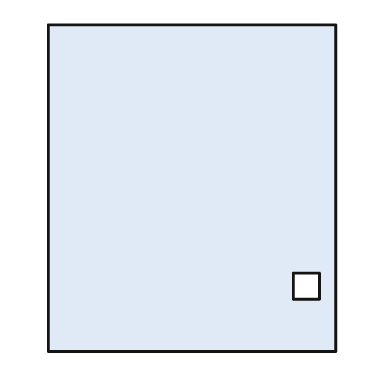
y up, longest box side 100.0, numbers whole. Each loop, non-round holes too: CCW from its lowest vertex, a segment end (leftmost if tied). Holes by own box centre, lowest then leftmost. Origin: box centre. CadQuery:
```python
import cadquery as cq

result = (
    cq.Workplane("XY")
    .moveTo(-44.0, -50.0)
    .lineTo(44.0, -50.0)
    .lineTo(44.0, 50.0)
    .lineTo(-44.0, 50.0)
    .close()
    .moveTo(31.0, -34.0)
    .lineTo(39.0, -34.0)
    .lineTo(39.0, -26.0)
    .lineTo(31.0, -26.0)
    .close()
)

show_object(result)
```